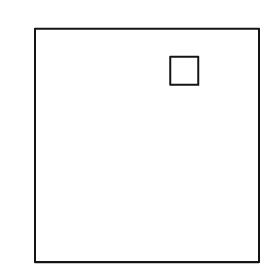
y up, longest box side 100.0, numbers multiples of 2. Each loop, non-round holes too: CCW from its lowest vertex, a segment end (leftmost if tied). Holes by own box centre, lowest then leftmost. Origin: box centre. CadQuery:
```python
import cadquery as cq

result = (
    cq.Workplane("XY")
    .moveTo(-48.0, -50.0)
    .lineTo(48.0, -50.0)
    .lineTo(48.0, 50.0)
    .lineTo(-48.0, 50.0)
    .close()
    .moveTo(10.0, 26.0)
    .lineTo(22.0, 26.0)
    .lineTo(22.0, 38.0)
    .lineTo(10.0, 38.0)
    .close()
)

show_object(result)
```